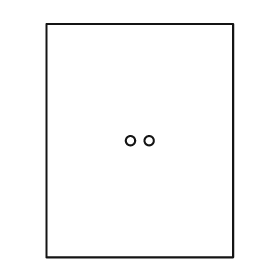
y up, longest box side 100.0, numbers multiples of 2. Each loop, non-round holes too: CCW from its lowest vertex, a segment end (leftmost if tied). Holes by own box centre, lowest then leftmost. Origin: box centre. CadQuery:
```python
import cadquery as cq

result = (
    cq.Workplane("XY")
    .moveTo(-40.0, -50.0)
    .lineTo(40.0, -50.0)
    .lineTo(40.0, 50.0)
    .lineTo(-40.0, 50.0)
    .close()
    .moveTo(-4.0, 0.0)
    .circle(2.0)
    .moveTo(4.0, 0.0)
    .circle(2.0)
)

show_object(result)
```